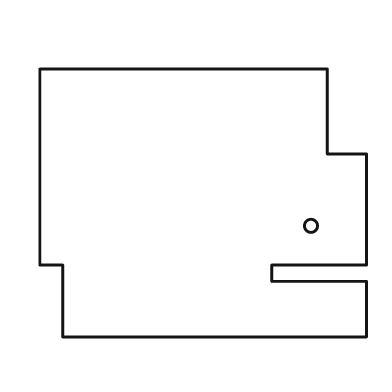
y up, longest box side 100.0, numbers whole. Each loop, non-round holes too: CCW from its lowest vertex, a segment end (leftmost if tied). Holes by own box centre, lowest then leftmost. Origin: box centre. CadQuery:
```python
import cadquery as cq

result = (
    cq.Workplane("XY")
    .moveTo(-43.0, -41.0)
    .lineTo(50.0, -41.0)
    .lineTo(50.0, -24.0)
    .lineTo(21.0, -24.0)
    .lineTo(21.0, -19.0)
    .lineTo(50.0, -19.0)
    .lineTo(50.0, 15.0)
    .lineTo(38.0, 15.0)
    .lineTo(38.0, 41.0)
    .lineTo(-50.0, 41.0)
    .lineTo(-50.0, -19.0)
    .lineTo(-43.0, -19.0)
    .close()
    .moveTo(33.0, -7.0)
    .circle(2.0)
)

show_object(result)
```